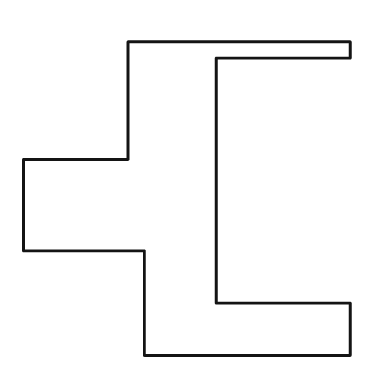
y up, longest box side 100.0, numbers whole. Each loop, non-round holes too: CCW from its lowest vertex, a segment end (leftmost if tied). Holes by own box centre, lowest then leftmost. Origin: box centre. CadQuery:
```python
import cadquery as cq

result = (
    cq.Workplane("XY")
    .moveTo(-13.0, -48.0)
    .lineTo(50.0, -48.0)
    .lineTo(50.0, -32.0)
    .lineTo(9.0, -32.0)
    .lineTo(9.0, 43.0)
    .lineTo(50.0, 43.0)
    .lineTo(50.0, 48.0)
    .lineTo(-18.0, 48.0)
    .lineTo(-18.0, 12.0)
    .lineTo(-50.0, 12.0)
    .lineTo(-50.0, -16.0)
    .lineTo(-13.0, -16.0)
    .close()
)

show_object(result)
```